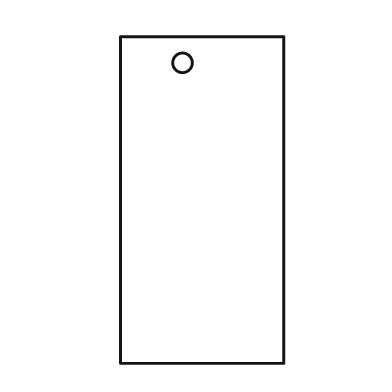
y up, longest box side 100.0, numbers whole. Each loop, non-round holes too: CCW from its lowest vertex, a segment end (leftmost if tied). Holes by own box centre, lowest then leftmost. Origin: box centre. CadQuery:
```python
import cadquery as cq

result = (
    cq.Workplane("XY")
    .moveTo(-25.0, -50.0)
    .lineTo(25.0, -50.0)
    .lineTo(25.0, 50.0)
    .lineTo(-25.0, 50.0)
    .close()
    .moveTo(-6.0, 42.0)
    .circle(3.0)
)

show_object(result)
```